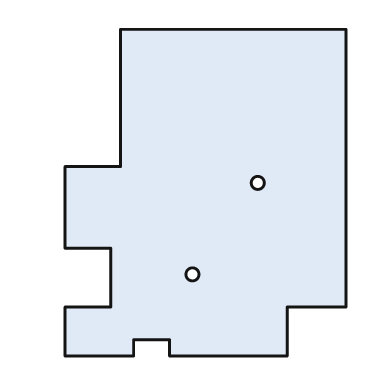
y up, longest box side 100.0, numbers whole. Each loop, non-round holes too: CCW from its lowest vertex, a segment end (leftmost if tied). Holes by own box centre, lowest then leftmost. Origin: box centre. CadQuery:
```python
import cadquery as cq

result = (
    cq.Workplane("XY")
    .moveTo(-43.0, -50.0)
    .lineTo(-22.0, -50.0)
    .lineTo(-22.0, -45.0)
    .lineTo(-11.0, -45.0)
    .lineTo(-11.0, -50.0)
    .lineTo(25.0, -50.0)
    .lineTo(25.0, -35.0)
    .lineTo(43.0, -35.0)
    .lineTo(43.0, 50.0)
    .lineTo(-26.0, 50.0)
    .lineTo(-26.0, 8.0)
    .lineTo(-43.0, 8.0)
    .lineTo(-43.0, -17.0)
    .lineTo(-29.0, -17.0)
    .lineTo(-29.0, -35.0)
    .lineTo(-43.0, -35.0)
    .close()
    .moveTo(-4.0, -25.0)
    .circle(2.0)
    .moveTo(16.0, 3.0)
    .circle(2.0)
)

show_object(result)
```